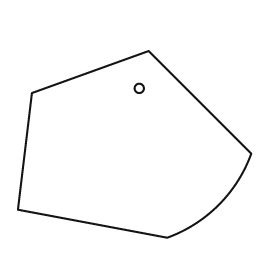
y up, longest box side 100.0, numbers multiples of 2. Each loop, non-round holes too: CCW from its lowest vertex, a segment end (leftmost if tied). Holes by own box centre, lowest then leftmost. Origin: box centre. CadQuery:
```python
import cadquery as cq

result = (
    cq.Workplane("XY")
    .moveTo(14.0, -40.0)
    .threePointArc((36.0, -26.0), (50.0, -4.0))
    .lineTo(6.0, 40.0)
    .lineTo(-44.0, 22.0)
    .lineTo(-50.0, -28.0)
    .close()
    .moveTo(2.0, 24.0)
    .circle(2.0)
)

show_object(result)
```